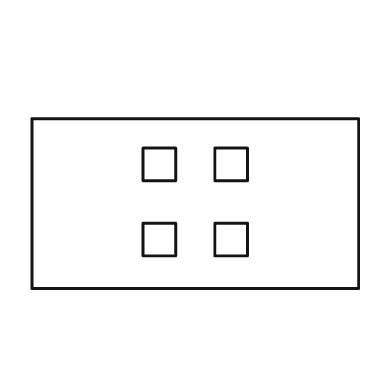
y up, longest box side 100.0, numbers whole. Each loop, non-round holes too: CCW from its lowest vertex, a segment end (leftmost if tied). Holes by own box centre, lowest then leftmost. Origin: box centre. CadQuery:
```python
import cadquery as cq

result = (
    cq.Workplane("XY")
    .moveTo(-50.0, -26.0)
    .lineTo(50.0, -26.0)
    .lineTo(50.0, 26.0)
    .lineTo(-50.0, 26.0)
    .close()
    .moveTo(-16.0, -16.0)
    .lineTo(-6.0, -16.0)
    .lineTo(-6.0, -6.0)
    .lineTo(-16.0, -6.0)
    .close()
    .moveTo(6.0, -16.0)
    .lineTo(16.0, -16.0)
    .lineTo(16.0, -6.0)
    .lineTo(6.0, -6.0)
    .close()
    .moveTo(-16.0, 7.0)
    .lineTo(-6.0, 7.0)
    .lineTo(-6.0, 17.0)
    .lineTo(-16.0, 17.0)
    .close()
    .moveTo(6.0, 7.0)
    .lineTo(16.0, 7.0)
    .lineTo(16.0, 17.0)
    .lineTo(6.0, 17.0)
    .close()
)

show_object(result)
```